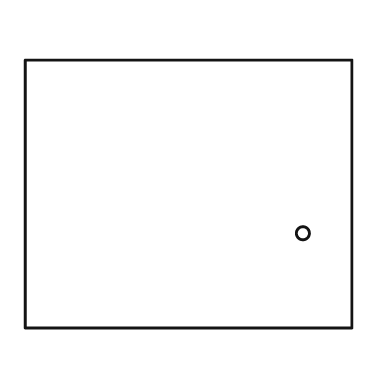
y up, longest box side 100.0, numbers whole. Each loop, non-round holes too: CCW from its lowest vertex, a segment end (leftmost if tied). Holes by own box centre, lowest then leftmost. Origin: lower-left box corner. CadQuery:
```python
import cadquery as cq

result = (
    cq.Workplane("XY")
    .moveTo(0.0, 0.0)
    .lineTo(100.0, 0.0)
    .lineTo(100.0, 82.0)
    .lineTo(0.0, 82.0)
    .close()
    .moveTo(85.0, 29.0)
    .circle(2.0)
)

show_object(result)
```